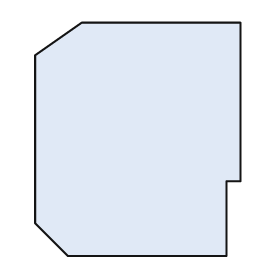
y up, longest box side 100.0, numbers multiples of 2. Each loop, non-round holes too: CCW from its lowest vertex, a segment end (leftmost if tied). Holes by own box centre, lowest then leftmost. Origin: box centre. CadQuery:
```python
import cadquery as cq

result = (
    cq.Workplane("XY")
    .moveTo(-30.0, -50.0)
    .lineTo(38.0, -50.0)
    .lineTo(38.0, -18.0)
    .lineTo(44.0, -18.0)
    .lineTo(44.0, 50.0)
    .lineTo(-24.0, 50.0)
    .lineTo(-44.0, 36.0)
    .lineTo(-44.0, -36.0)
    .close()
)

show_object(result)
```